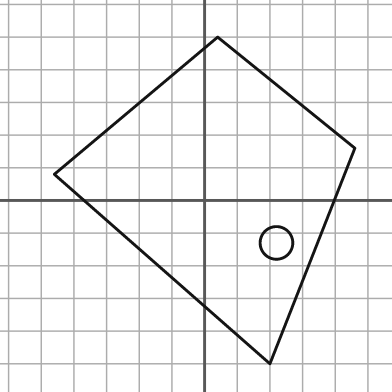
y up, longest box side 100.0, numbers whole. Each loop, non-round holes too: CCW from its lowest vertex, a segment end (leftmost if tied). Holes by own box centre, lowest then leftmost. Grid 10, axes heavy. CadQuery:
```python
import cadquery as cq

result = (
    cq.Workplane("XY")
    .moveTo(20.0, -50.0)
    .lineTo(46.0, 16.0)
    .lineTo(4.0, 50.0)
    .lineTo(-46.0, 8.0)
    .close()
    .moveTo(22.0, -13.0)
    .circle(5.0)
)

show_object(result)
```